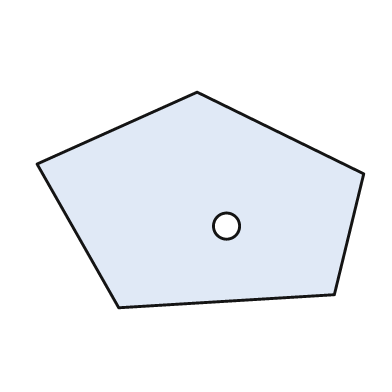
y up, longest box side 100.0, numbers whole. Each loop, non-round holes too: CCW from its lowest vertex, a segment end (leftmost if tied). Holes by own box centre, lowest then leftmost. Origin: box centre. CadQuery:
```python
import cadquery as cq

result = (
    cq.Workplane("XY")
    .moveTo(-25.0, -33.0)
    .lineTo(41.0, -29.0)
    .lineTo(50.0, 8.0)
    .lineTo(-1.0, 33.0)
    .lineTo(-50.0, 11.0)
    .close()
    .moveTo(8.0, -8.0)
    .circle(4.0)
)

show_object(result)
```